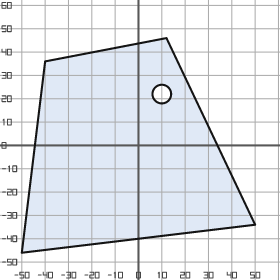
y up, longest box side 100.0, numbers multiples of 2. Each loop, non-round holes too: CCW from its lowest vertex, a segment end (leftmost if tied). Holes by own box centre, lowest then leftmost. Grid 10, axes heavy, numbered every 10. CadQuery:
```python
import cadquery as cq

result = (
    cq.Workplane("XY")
    .moveTo(-50.0, -46.0)
    .lineTo(50.0, -34.0)
    .lineTo(12.0, 46.0)
    .lineTo(-40.0, 36.0)
    .close()
    .moveTo(10.0, 22.0)
    .circle(4.0)
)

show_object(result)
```